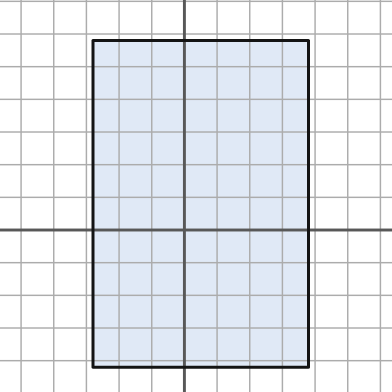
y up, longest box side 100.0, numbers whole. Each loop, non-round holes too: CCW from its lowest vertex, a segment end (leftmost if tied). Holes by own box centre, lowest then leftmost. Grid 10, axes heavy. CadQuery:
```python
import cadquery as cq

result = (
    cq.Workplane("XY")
    .moveTo(-28.0, -42.0)
    .lineTo(38.0, -42.0)
    .lineTo(38.0, 58.0)
    .lineTo(-28.0, 58.0)
    .close()
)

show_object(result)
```